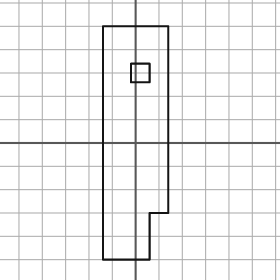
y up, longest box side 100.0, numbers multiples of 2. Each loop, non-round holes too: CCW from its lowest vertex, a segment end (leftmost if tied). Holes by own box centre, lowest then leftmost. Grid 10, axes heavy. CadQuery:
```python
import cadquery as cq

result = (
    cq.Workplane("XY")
    .moveTo(-14.0, -50.0)
    .lineTo(6.0, -50.0)
    .lineTo(6.0, -30.0)
    .lineTo(14.0, -30.0)
    .lineTo(14.0, 50.0)
    .lineTo(-14.0, 50.0)
    .close()
    .moveTo(-2.0, 26.0)
    .lineTo(6.0, 26.0)
    .lineTo(6.0, 34.0)
    .lineTo(-2.0, 34.0)
    .close()
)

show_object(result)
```